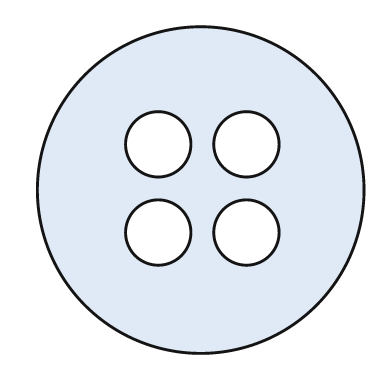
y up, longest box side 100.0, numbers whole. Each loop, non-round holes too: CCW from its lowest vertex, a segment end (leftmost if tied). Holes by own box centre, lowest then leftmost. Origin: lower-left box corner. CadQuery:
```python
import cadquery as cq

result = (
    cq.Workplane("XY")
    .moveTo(50.0, 50.0)
    .circle(50.0)
    .moveTo(37.0, 37.0)
    .circle(10.0)
    .moveTo(64.0, 37.0)
    .circle(10.0)
    .moveTo(37.0, 64.0)
    .circle(10.0)
    .moveTo(64.0, 64.0)
    .circle(10.0)
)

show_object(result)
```